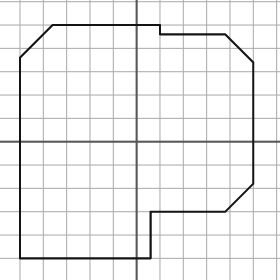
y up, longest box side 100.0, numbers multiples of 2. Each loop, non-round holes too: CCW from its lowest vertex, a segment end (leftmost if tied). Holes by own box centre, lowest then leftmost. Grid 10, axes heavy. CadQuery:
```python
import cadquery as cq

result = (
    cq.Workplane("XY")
    .moveTo(-50.0, -50.0)
    .lineTo(6.0, -50.0)
    .lineTo(6.0, -30.0)
    .lineTo(38.0, -30.0)
    .lineTo(50.0, -18.0)
    .lineTo(50.0, 34.0)
    .lineTo(38.0, 46.0)
    .lineTo(10.0, 46.0)
    .lineTo(10.0, 50.0)
    .lineTo(-36.0, 50.0)
    .lineTo(-50.0, 36.0)
    .close()
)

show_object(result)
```